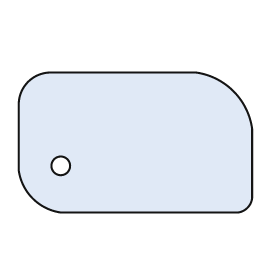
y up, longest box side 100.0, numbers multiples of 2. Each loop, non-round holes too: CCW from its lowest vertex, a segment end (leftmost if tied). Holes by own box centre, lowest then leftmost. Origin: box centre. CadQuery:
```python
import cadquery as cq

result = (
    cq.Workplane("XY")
    .moveTo(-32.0, -30.0)
    .lineTo(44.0, -30.0)
    .threePointArc((48.0, -28.0), (50.0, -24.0))
    .lineTo(50.0, 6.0)
    .threePointArc((42.0, 22.0), (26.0, 30.0))
    .lineTo(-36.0, 30.0)
    .threePointArc((-46.0, 26.0), (-50.0, 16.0))
    .lineTo(-50.0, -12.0)
    .threePointArc((-44.0, -24.0), (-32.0, -30.0))
    .close()
    .moveTo(-32.0, -10.0)
    .circle(4.0)
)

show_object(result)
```